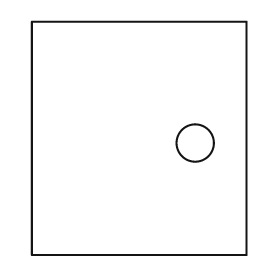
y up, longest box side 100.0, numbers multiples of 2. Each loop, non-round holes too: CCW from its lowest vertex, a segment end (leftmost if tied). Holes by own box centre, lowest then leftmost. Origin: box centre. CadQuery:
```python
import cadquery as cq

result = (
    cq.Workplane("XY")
    .moveTo(-46.0, -50.0)
    .lineTo(46.0, -50.0)
    .lineTo(46.0, 50.0)
    .lineTo(-46.0, 50.0)
    .close()
    .moveTo(24.0, -2.0)
    .circle(8.0)
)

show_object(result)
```